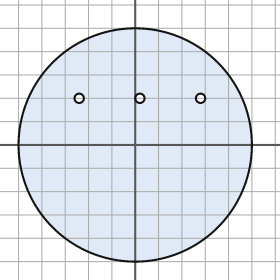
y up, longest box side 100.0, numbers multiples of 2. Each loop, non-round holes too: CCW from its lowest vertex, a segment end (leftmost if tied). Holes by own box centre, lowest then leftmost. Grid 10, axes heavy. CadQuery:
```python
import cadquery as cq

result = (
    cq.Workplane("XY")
    .moveTo(0.0, 0.0)
    .circle(50.0)
    .moveTo(-24.0, 20.0)
    .circle(2.0)
    .moveTo(2.0, 20.0)
    .circle(2.0)
    .moveTo(28.0, 20.0)
    .circle(2.0)
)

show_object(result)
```